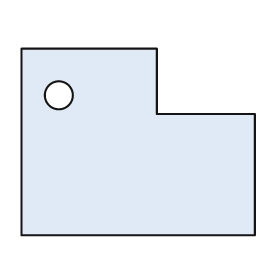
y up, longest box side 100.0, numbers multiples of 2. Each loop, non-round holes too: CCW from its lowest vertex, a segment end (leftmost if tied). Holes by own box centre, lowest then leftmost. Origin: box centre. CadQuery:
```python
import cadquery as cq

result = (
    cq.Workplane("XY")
    .moveTo(-50.0, -40.0)
    .lineTo(50.0, -40.0)
    .lineTo(50.0, 12.0)
    .lineTo(8.0, 12.0)
    .lineTo(8.0, 40.0)
    .lineTo(-50.0, 40.0)
    .close()
    .moveTo(-34.0, 20.0)
    .circle(6.0)
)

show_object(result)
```